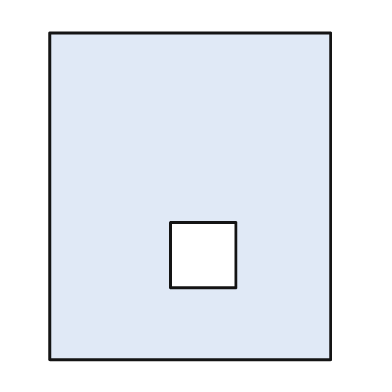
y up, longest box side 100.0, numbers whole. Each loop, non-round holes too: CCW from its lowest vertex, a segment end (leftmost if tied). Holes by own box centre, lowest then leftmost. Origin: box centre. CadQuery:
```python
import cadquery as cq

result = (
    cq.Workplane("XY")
    .moveTo(-43.0, -50.0)
    .lineTo(43.0, -50.0)
    .lineTo(43.0, 50.0)
    .lineTo(-43.0, 50.0)
    .close()
    .moveTo(-6.0, -28.0)
    .lineTo(14.0, -28.0)
    .lineTo(14.0, -8.0)
    .lineTo(-6.0, -8.0)
    .close()
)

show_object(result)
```